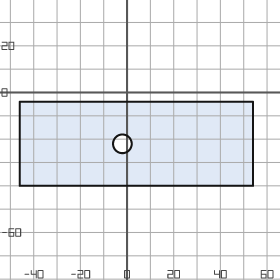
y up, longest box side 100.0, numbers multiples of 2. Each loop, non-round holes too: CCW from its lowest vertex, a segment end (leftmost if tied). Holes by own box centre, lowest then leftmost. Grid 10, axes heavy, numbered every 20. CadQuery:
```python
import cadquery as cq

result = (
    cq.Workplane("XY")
    .moveTo(-46.0, -40.0)
    .lineTo(54.0, -40.0)
    .lineTo(54.0, -4.0)
    .lineTo(-46.0, -4.0)
    .close()
    .moveTo(-2.0, -22.0)
    .circle(4.0)
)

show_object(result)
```